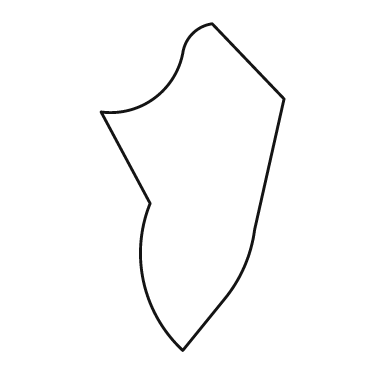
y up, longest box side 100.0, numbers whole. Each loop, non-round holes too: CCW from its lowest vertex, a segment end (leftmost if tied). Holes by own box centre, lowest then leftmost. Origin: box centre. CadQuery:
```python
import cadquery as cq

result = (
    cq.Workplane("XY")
    .moveTo(-3.0, -50.0)
    .lineTo(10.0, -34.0)
    .threePointArc((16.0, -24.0), (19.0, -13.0))
    .lineTo(28.0, 27.0)
    .lineTo(6.0, 50.0)
    .threePointArc((0.0, 47.0), (-3.0, 41.0))
    .threePointArc((-12.0, 27.0), (-28.0, 23.0))
    .lineTo(-13.0, -5.0)
    .threePointArc((-15.0, -29.0), (-3.0, -50.0))
    .close()
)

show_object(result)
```